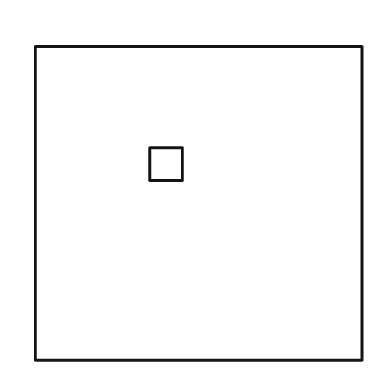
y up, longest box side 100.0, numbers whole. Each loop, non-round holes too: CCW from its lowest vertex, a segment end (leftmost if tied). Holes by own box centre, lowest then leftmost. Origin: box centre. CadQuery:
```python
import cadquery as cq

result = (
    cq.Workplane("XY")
    .moveTo(-50.0, -48.0)
    .lineTo(50.0, -48.0)
    .lineTo(50.0, 48.0)
    .lineTo(-50.0, 48.0)
    .close()
    .moveTo(-15.0, 7.0)
    .lineTo(-5.0, 7.0)
    .lineTo(-5.0, 17.0)
    .lineTo(-15.0, 17.0)
    .close()
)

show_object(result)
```